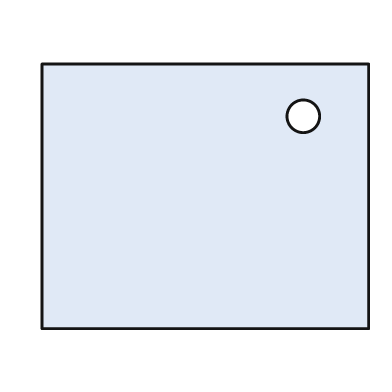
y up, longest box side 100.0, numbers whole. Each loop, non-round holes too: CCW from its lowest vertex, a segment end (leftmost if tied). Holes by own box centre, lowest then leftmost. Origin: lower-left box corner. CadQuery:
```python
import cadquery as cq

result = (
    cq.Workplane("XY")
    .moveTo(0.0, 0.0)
    .lineTo(100.0, 0.0)
    .lineTo(100.0, 81.0)
    .lineTo(0.0, 81.0)
    .close()
    .moveTo(80.0, 65.0)
    .circle(5.0)
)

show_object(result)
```